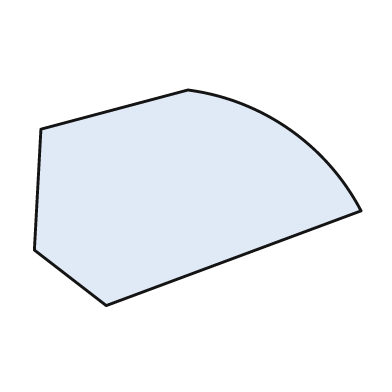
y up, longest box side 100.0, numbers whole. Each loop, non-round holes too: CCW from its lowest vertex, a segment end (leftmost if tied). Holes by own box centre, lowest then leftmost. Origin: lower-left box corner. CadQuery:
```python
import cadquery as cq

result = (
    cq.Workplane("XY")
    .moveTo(22.0, 0.0)
    .lineTo(100.0, 29.0)
    .threePointArc((78.0, 54.0), (47.0, 66.0))
    .lineTo(2.0, 54.0)
    .lineTo(0.0, 17.0)
    .close()
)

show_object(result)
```